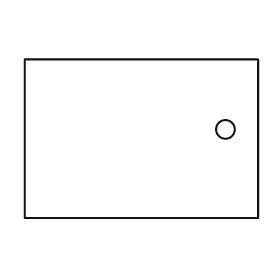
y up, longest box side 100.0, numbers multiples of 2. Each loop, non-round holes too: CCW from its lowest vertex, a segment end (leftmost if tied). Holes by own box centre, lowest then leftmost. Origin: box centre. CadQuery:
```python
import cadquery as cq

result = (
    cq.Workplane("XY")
    .moveTo(-50.0, -34.0)
    .lineTo(50.0, -34.0)
    .lineTo(50.0, 34.0)
    .lineTo(-50.0, 34.0)
    .close()
    .moveTo(36.0, 4.0)
    .circle(4.0)
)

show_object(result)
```